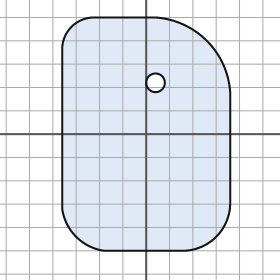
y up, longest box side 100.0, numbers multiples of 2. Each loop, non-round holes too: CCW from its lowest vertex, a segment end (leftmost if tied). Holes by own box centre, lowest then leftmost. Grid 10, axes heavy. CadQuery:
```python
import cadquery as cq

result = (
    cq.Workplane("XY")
    .moveTo(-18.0, -50.0)
    .lineTo(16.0, -50.0)
    .threePointArc((30.0, -44.0), (36.0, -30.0))
    .lineTo(36.0, 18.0)
    .threePointArc((26.0, 40.0), (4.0, 50.0))
    .lineTo(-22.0, 50.0)
    .threePointArc((-32.0, 46.0), (-36.0, 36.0))
    .lineTo(-36.0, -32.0)
    .threePointArc((-30.0, -44.0), (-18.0, -50.0))
    .close()
    .moveTo(4.0, 22.0)
    .circle(4.0)
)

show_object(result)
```